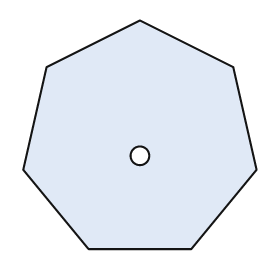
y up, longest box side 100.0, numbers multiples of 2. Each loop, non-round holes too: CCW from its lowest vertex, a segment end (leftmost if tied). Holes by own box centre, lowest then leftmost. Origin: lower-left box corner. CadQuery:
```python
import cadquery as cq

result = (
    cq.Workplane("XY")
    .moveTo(28.0, 0.0)
    .lineTo(72.0, 0.0)
    .lineTo(100.0, 34.0)
    .lineTo(90.0, 78.0)
    .lineTo(50.0, 98.0)
    .lineTo(10.0, 78.0)
    .lineTo(0.0, 34.0)
    .close()
    .moveTo(50.0, 40.0)
    .circle(4.0)
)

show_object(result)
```